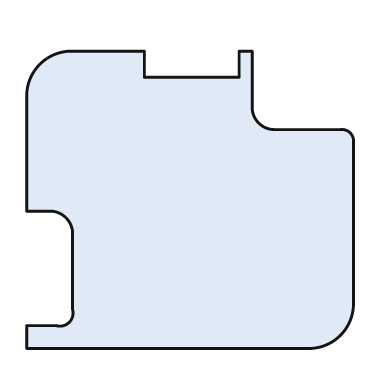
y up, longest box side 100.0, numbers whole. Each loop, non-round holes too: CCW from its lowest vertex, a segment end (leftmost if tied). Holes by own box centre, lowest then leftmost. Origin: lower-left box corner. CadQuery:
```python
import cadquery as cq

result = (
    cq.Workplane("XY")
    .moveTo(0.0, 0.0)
    .lineTo(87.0, 0.0)
    .threePointArc((96.0, 4.0), (100.0, 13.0))
    .lineTo(100.0, 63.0)
    .threePointArc((99.0, 66.0), (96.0, 67.0))
    .lineTo(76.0, 67.0)
    .threePointArc((71.0, 69.0), (69.0, 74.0))
    .lineTo(69.0, 91.0)
    .lineTo(65.0, 91.0)
    .lineTo(65.0, 83.0)
    .lineTo(36.0, 83.0)
    .lineTo(36.0, 91.0)
    .lineTo(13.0, 91.0)
    .threePointArc((4.0, 87.0), (0.0, 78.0))
    .lineTo(0.0, 42.0)
    .lineTo(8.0, 42.0)
    .threePointArc((12.0, 40.0), (14.0, 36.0))
    .lineTo(14.0, 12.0)
    .threePointArc((13.0, 8.0), (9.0, 7.0))
    .lineTo(0.0, 7.0)
    .close()
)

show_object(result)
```